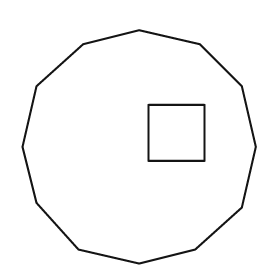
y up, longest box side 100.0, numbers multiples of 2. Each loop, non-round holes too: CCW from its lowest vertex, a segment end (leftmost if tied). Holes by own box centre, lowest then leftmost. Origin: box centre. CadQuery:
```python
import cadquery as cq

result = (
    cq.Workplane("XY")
    .moveTo(0.0, -50.0)
    .lineTo(24.0, -44.0)
    .lineTo(44.0, -26.0)
    .lineTo(50.0, 0.0)
    .lineTo(44.0, 26.0)
    .lineTo(26.0, 44.0)
    .lineTo(0.0, 50.0)
    .lineTo(-24.0, 44.0)
    .lineTo(-44.0, 26.0)
    .lineTo(-50.0, 0.0)
    .lineTo(-44.0, -24.0)
    .lineTo(-26.0, -44.0)
    .close()
    .moveTo(4.0, -6.0)
    .lineTo(28.0, -6.0)
    .lineTo(28.0, 18.0)
    .lineTo(4.0, 18.0)
    .close()
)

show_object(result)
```